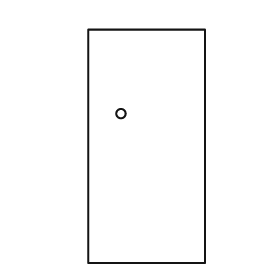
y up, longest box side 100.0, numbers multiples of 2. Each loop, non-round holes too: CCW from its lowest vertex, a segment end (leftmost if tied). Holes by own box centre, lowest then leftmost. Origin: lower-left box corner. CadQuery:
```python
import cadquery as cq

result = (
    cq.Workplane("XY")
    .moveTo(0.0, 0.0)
    .lineTo(50.0, 0.0)
    .lineTo(50.0, 100.0)
    .lineTo(0.0, 100.0)
    .close()
    .moveTo(14.0, 64.0)
    .circle(2.0)
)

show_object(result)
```